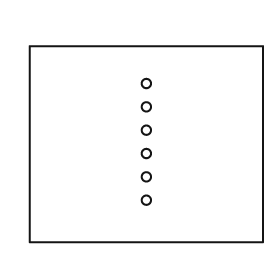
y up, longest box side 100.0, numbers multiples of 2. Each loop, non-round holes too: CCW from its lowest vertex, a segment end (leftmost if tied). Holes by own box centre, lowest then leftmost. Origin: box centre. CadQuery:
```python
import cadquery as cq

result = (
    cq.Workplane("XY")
    .moveTo(-50.0, -42.0)
    .lineTo(50.0, -42.0)
    .lineTo(50.0, 42.0)
    .lineTo(-50.0, 42.0)
    .close()
    .moveTo(0.0, -24.0)
    .circle(2.0)
    .moveTo(0.0, -14.0)
    .circle(2.0)
    .moveTo(0.0, -4.0)
    .circle(2.0)
    .moveTo(0.0, 6.0)
    .circle(2.0)
    .moveTo(0.0, 16.0)
    .circle(2.0)
    .moveTo(0.0, 26.0)
    .circle(2.0)
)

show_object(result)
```